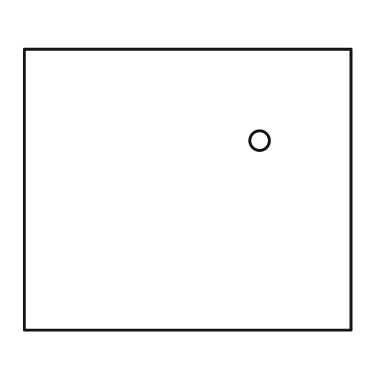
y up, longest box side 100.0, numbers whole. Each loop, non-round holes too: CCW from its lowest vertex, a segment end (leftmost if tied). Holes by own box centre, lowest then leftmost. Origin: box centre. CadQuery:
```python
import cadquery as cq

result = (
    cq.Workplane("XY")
    .moveTo(-50.0, -43.0)
    .lineTo(50.0, -43.0)
    .lineTo(50.0, 43.0)
    .lineTo(-50.0, 43.0)
    .close()
    .moveTo(22.0, 15.0)
    .circle(3.0)
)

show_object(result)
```